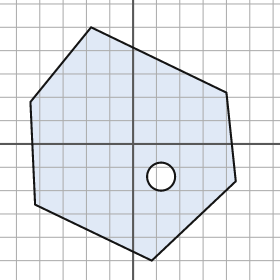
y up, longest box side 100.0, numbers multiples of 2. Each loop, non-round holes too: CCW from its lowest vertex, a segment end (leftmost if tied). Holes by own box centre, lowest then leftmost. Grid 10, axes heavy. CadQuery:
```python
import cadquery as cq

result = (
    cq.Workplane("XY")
    .moveTo(8.0, -50.0)
    .lineTo(44.0, -16.0)
    .lineTo(40.0, 22.0)
    .lineTo(-18.0, 50.0)
    .lineTo(-44.0, 18.0)
    .lineTo(-42.0, -26.0)
    .close()
    .moveTo(12.0, -14.0)
    .circle(6.0)
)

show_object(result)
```